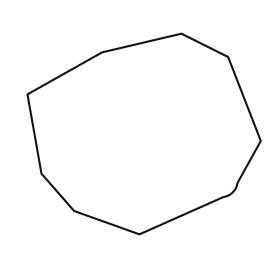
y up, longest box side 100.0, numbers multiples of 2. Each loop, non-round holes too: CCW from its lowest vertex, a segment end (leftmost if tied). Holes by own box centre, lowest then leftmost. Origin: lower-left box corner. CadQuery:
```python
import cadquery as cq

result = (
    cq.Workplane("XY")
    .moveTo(48.0, 0.0)
    .lineTo(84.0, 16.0)
    .threePointArc((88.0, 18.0), (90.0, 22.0))
    .lineTo(100.0, 40.0)
    .lineTo(86.0, 76.0)
    .lineTo(66.0, 86.0)
    .lineTo(32.0, 78.0)
    .lineTo(0.0, 60.0)
    .lineTo(6.0, 26.0)
    .lineTo(20.0, 10.0)
    .close()
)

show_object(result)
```